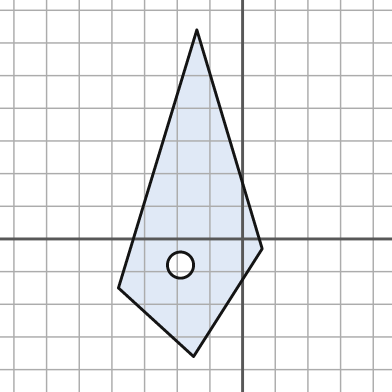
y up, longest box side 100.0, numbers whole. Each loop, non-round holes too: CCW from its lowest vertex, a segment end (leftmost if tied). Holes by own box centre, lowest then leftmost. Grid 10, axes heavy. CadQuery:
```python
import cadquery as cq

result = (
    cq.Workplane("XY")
    .moveTo(-15.0, -36.0)
    .lineTo(6.0, -3.0)
    .lineTo(-14.0, 64.0)
    .lineTo(-38.0, -15.0)
    .close()
    .moveTo(-19.0, -8.0)
    .circle(4.0)
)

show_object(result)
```